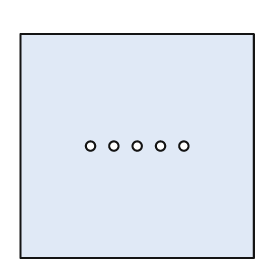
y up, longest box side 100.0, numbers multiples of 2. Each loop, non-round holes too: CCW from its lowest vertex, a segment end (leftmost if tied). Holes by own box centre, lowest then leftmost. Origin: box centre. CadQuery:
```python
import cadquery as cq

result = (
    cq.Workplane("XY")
    .moveTo(-50.0, -48.0)
    .lineTo(50.0, -48.0)
    .lineTo(50.0, 48.0)
    .lineTo(-50.0, 48.0)
    .close()
    .moveTo(-20.0, 0.0)
    .circle(2.0)
    .moveTo(-10.0, 0.0)
    .circle(2.0)
    .moveTo(0.0, 0.0)
    .circle(2.0)
    .moveTo(10.0, 0.0)
    .circle(2.0)
    .moveTo(20.0, 0.0)
    .circle(2.0)
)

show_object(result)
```